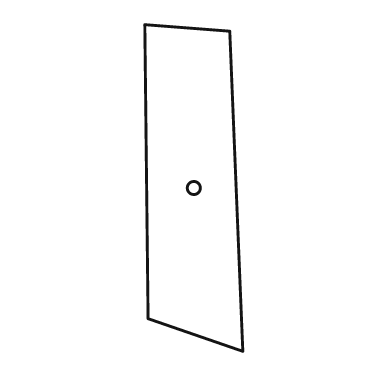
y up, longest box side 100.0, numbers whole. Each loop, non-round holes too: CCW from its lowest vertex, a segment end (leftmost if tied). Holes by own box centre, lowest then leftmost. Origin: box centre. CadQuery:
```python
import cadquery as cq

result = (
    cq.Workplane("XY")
    .moveTo(15.0, -50.0)
    .lineTo(11.0, 48.0)
    .lineTo(-15.0, 50.0)
    .lineTo(-14.0, -40.0)
    .close()
    .moveTo(0.0, 0.0)
    .circle(2.0)
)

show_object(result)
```